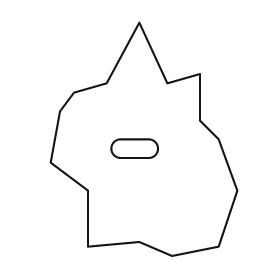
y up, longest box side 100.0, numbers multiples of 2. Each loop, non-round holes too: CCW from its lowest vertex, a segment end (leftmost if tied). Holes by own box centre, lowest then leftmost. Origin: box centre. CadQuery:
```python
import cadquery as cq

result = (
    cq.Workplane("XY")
    .moveTo(12.0, -50.0)
    .lineTo(32.0, -46.0)
    .lineTo(40.0, -22.0)
    .lineTo(32.0, 0.0)
    .lineTo(24.0, 8.0)
    .lineTo(24.0, 28.0)
    .lineTo(10.0, 24.0)
    .lineTo(-2.0, 50.0)
    .lineTo(-16.0, 24.0)
    .lineTo(-30.0, 20.0)
    .lineTo(-36.0, 12.0)
    .lineTo(-40.0, -10.0)
    .lineTo(-24.0, -22.0)
    .lineTo(-24.0, -46.0)
    .lineTo(-2.0, -44.0)
    .close()
    .moveTo(-10.0, -8.0)
    .lineTo(2.0, -8.0)
    .threePointArc((6.0, -4.0), (2.0, 0.0))
    .lineTo(-10.0, 0.0)
    .threePointArc((-14.0, -4.0), (-10.0, -8.0))
    .close()
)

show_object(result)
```